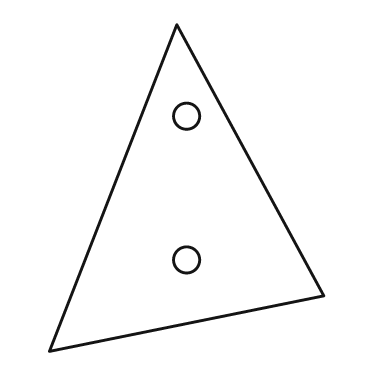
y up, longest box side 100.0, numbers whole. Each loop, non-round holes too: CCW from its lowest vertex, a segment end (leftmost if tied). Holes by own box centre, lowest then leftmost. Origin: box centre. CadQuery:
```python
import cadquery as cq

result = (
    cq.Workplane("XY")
    .moveTo(-42.0, -50.0)
    .lineTo(42.0, -33.0)
    .lineTo(-3.0, 50.0)
    .close()
    .moveTo(0.0, -22.0)
    .circle(4.0)
    .moveTo(0.0, 22.0)
    .circle(4.0)
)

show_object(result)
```